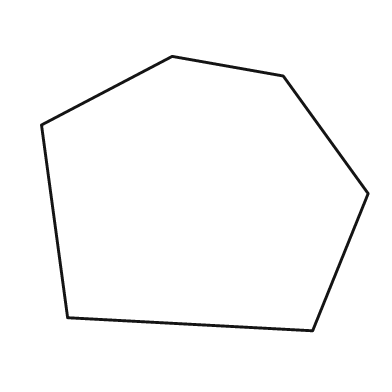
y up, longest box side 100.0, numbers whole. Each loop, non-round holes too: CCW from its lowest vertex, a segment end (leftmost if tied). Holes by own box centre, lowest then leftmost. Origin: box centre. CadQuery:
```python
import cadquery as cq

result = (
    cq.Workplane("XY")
    .moveTo(33.0, -42.0)
    .lineTo(50.0, 0.0)
    .lineTo(24.0, 36.0)
    .lineTo(-10.0, 42.0)
    .lineTo(-50.0, 21.0)
    .lineTo(-42.0, -38.0)
    .close()
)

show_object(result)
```